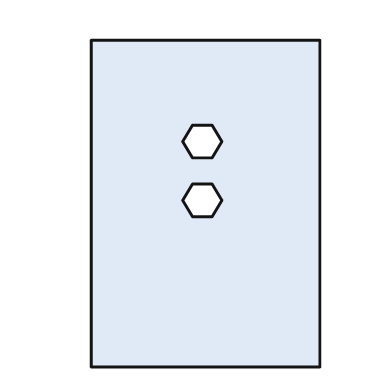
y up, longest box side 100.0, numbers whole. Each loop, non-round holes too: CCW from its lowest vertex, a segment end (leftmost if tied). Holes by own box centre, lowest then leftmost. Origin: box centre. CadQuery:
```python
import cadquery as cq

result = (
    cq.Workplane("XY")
    .moveTo(-35.0, -50.0)
    .lineTo(35.0, -50.0)
    .lineTo(35.0, 50.0)
    .lineTo(-35.0, 50.0)
    .close()
    .moveTo(-4.0, -4.0)
    .lineTo(2.0, -4.0)
    .lineTo(5.0, 1.0)
    .lineTo(2.0, 6.0)
    .lineTo(-4.0, 6.0)
    .lineTo(-7.0, 1.0)
    .close()
    .moveTo(-4.0, 14.0)
    .lineTo(2.0, 14.0)
    .lineTo(5.0, 19.0)
    .lineTo(2.0, 24.0)
    .lineTo(-4.0, 24.0)
    .lineTo(-7.0, 19.0)
    .close()
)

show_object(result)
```